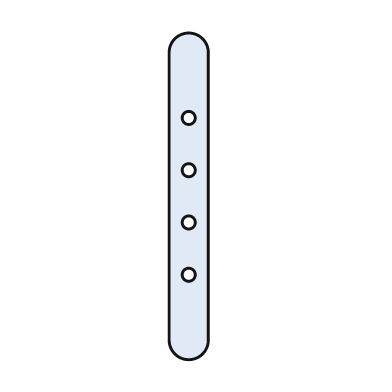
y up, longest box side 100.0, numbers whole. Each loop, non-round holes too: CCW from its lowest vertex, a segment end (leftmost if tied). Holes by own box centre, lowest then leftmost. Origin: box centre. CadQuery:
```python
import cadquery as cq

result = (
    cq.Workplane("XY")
    .moveTo(-6.0, -44.0)
    .threePointArc((0.0, -50.0), (6.0, -44.0))
    .lineTo(6.0, 44.0)
    .threePointArc((0.0, 50.0), (-6.0, 44.0))
    .close()
    .moveTo(0.0, -24.0)
    .circle(2.0)
    .moveTo(0.0, -8.0)
    .circle(2.0)
    .moveTo(0.0, 8.0)
    .circle(2.0)
    .moveTo(0.0, 24.0)
    .circle(2.0)
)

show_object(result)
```